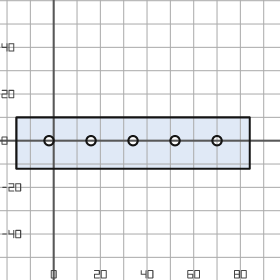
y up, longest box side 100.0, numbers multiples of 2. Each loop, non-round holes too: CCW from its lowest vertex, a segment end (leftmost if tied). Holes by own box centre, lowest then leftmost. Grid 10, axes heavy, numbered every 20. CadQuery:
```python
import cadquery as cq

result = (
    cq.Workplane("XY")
    .moveTo(-16.0, -12.0)
    .lineTo(84.0, -12.0)
    .lineTo(84.0, 10.0)
    .lineTo(-16.0, 10.0)
    .close()
    .moveTo(-2.0, 0.0)
    .circle(2.0)
    .moveTo(16.0, 0.0)
    .circle(2.0)
    .moveTo(34.0, 0.0)
    .circle(2.0)
    .moveTo(52.0, 0.0)
    .circle(2.0)
    .moveTo(70.0, 0.0)
    .circle(2.0)
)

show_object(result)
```